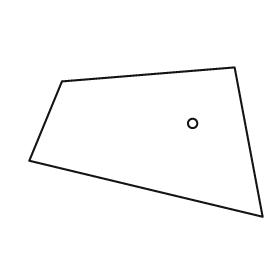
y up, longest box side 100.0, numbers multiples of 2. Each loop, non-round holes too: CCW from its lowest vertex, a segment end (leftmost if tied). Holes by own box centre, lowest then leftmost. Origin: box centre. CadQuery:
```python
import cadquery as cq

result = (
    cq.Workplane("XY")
    .moveTo(50.0, -32.0)
    .lineTo(38.0, 32.0)
    .lineTo(-36.0, 26.0)
    .lineTo(-50.0, -8.0)
    .close()
    .moveTo(20.0, 8.0)
    .circle(2.0)
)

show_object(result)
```